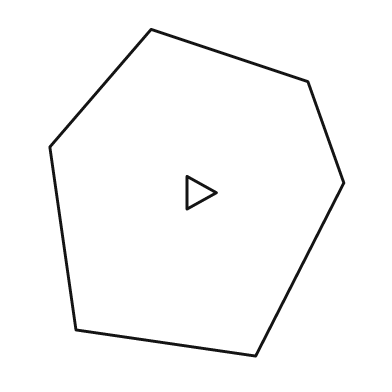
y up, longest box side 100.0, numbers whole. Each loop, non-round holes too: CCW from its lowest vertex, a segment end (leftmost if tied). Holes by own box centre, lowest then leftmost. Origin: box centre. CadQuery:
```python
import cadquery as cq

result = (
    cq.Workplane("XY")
    .moveTo(18.0, -50.0)
    .lineTo(45.0, 3.0)
    .lineTo(34.0, 34.0)
    .lineTo(-14.0, 50.0)
    .lineTo(-45.0, 14.0)
    .lineTo(-37.0, -42.0)
    .close()
    .moveTo(-3.0, -5.0)
    .lineTo(6.0, 0.0)
    .lineTo(-3.0, 5.0)
    .close()
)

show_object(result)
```